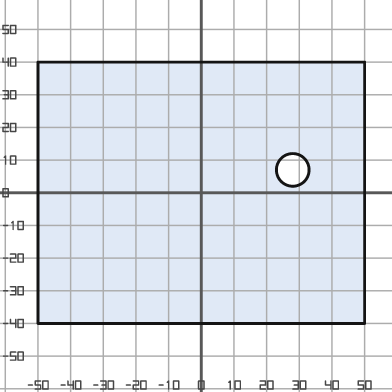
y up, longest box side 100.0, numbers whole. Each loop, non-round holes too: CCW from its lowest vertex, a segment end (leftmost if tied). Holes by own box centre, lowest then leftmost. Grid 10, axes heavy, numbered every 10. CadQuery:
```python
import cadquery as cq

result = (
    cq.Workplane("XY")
    .moveTo(-50.0, -40.0)
    .lineTo(50.0, -40.0)
    .lineTo(50.0, 40.0)
    .lineTo(-50.0, 40.0)
    .close()
    .moveTo(28.0, 7.0)
    .circle(5.0)
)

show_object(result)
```